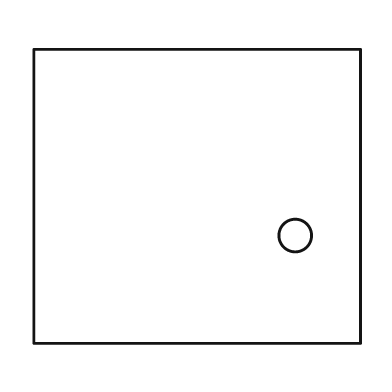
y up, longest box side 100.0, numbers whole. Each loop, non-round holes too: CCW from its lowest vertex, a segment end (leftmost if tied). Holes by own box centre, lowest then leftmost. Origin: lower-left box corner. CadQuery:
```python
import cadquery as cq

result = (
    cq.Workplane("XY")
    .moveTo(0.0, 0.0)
    .lineTo(100.0, 0.0)
    .lineTo(100.0, 90.0)
    .lineTo(0.0, 90.0)
    .close()
    .moveTo(80.0, 33.0)
    .circle(5.0)
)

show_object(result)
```